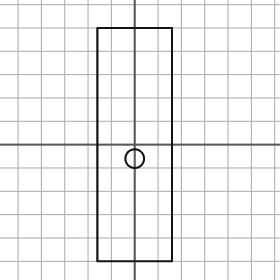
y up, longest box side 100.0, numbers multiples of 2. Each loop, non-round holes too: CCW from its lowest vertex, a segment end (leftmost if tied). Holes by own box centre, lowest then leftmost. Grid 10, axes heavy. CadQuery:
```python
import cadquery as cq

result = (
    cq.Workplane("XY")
    .moveTo(-16.0, -50.0)
    .lineTo(16.0, -50.0)
    .lineTo(16.0, 50.0)
    .lineTo(-16.0, 50.0)
    .close()
    .moveTo(0.0, -6.0)
    .circle(4.0)
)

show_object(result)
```